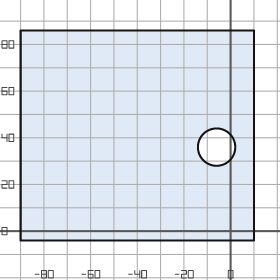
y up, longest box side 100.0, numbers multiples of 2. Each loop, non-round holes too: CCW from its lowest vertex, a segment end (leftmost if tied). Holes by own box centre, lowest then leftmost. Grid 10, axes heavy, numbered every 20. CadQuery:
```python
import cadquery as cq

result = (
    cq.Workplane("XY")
    .moveTo(-90.0, -4.0)
    .lineTo(10.0, -4.0)
    .lineTo(10.0, 86.0)
    .lineTo(-90.0, 86.0)
    .close()
    .moveTo(-6.0, 36.0)
    .circle(8.0)
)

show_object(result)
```